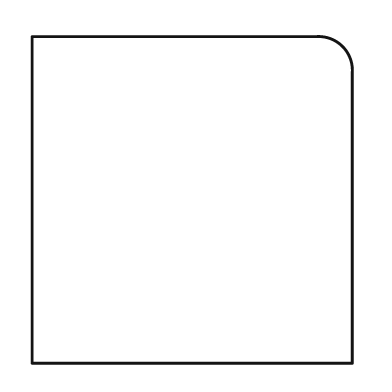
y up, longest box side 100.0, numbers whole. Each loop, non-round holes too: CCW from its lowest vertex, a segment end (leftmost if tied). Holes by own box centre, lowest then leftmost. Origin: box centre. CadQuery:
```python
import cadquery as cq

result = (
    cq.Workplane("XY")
    .moveTo(-49.0, -50.0)
    .lineTo(49.0, -50.0)
    .lineTo(49.0, 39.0)
    .threePointArc((46.0, 47.0), (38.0, 50.0))
    .lineTo(-49.0, 50.0)
    .close()
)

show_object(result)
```